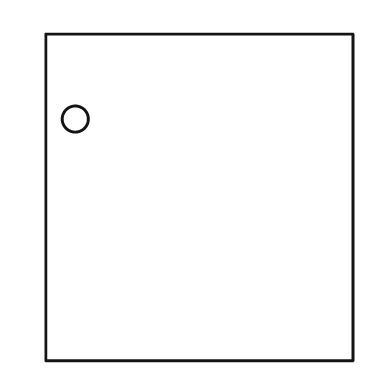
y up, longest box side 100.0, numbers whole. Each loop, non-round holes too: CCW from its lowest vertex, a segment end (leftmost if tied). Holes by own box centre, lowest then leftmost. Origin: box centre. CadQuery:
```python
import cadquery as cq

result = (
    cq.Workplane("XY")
    .moveTo(-47.0, -50.0)
    .lineTo(47.0, -50.0)
    .lineTo(47.0, 50.0)
    .lineTo(-47.0, 50.0)
    .close()
    .moveTo(-38.0, 24.0)
    .circle(4.0)
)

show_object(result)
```